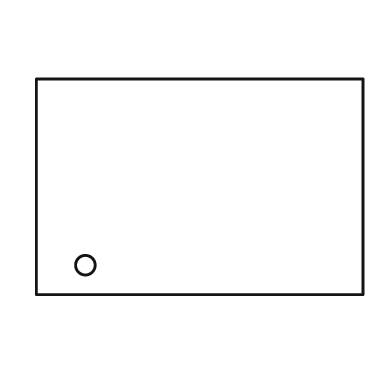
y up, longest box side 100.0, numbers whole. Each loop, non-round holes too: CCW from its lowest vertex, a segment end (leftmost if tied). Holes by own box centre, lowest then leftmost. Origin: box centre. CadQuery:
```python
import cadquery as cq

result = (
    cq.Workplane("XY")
    .moveTo(-50.0, -33.0)
    .lineTo(50.0, -33.0)
    .lineTo(50.0, 33.0)
    .lineTo(-50.0, 33.0)
    .close()
    .moveTo(-35.0, -24.0)
    .circle(3.0)
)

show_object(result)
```